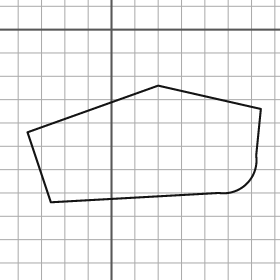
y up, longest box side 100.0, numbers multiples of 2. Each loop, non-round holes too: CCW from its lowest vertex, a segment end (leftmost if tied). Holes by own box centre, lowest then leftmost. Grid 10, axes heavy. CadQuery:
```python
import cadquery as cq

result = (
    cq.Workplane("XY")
    .moveTo(-26.0, -74.0)
    .lineTo(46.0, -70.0)
    .threePointArc((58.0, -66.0), (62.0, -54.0))
    .lineTo(64.0, -34.0)
    .lineTo(20.0, -24.0)
    .lineTo(-36.0, -44.0)
    .close()
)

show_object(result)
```